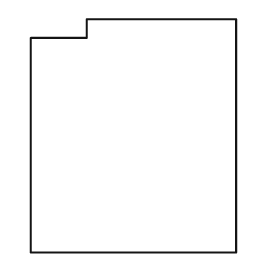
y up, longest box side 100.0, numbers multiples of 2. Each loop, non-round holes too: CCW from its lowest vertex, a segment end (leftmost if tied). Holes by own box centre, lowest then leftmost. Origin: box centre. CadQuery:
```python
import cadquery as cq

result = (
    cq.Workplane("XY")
    .moveTo(-44.0, -50.0)
    .lineTo(44.0, -50.0)
    .lineTo(44.0, 50.0)
    .lineTo(-20.0, 50.0)
    .lineTo(-20.0, 42.0)
    .lineTo(-44.0, 42.0)
    .close()
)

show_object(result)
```